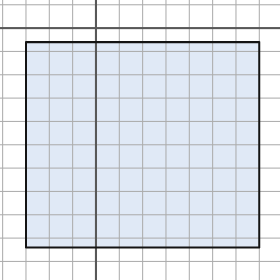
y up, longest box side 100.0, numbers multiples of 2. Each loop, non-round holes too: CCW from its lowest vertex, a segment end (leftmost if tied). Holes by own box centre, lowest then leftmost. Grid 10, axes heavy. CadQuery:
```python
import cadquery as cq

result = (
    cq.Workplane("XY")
    .moveTo(-30.0, -94.0)
    .lineTo(70.0, -94.0)
    .lineTo(70.0, -6.0)
    .lineTo(-30.0, -6.0)
    .close()
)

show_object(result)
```